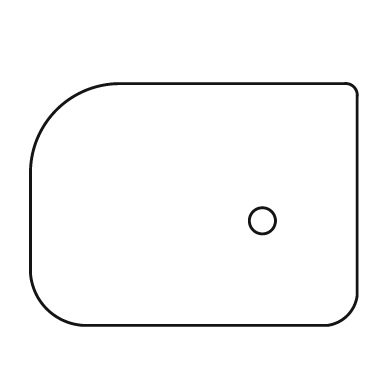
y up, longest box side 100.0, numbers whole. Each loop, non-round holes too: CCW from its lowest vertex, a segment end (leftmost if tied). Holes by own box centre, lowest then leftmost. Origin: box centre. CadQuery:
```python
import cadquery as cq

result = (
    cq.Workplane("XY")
    .moveTo(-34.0, -37.0)
    .lineTo(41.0, -37.0)
    .threePointArc((47.0, -34.0), (50.0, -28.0))
    .lineTo(50.0, 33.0)
    .threePointArc((49.0, 36.0), (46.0, 37.0))
    .lineTo(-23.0, 37.0)
    .threePointArc((-42.0, 29.0), (-50.0, 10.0))
    .lineTo(-50.0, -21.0)
    .threePointArc((-45.0, -32.0), (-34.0, -37.0))
    .close()
    .moveTo(21.0, -5.0)
    .circle(4.0)
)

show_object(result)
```